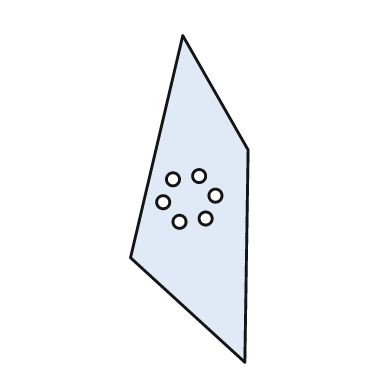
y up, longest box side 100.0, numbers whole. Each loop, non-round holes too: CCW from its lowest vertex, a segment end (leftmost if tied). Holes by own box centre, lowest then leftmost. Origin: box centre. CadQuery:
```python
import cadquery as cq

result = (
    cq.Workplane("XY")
    .moveTo(17.0, -50.0)
    .lineTo(18.0, 15.0)
    .lineTo(-2.0, 50.0)
    .lineTo(-18.0, -18.0)
    .close()
    .moveTo(-3.0, -7.0)
    .circle(2.0)
    .moveTo(5.0, -6.0)
    .circle(2.0)
    .moveTo(-8.0, -1.0)
    .circle(2.0)
    .moveTo(8.0, 1.0)
    .circle(2.0)
    .moveTo(-5.0, 6.0)
    .circle(2.0)
    .moveTo(3.0, 7.0)
    .circle(2.0)
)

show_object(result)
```